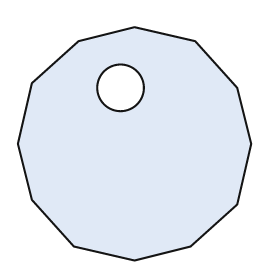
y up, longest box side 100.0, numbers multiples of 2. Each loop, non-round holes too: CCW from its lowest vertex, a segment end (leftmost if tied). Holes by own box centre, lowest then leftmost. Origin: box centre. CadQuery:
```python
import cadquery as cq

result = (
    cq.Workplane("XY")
    .moveTo(0.0, -50.0)
    .lineTo(24.0, -44.0)
    .lineTo(44.0, -26.0)
    .lineTo(50.0, 0.0)
    .lineTo(44.0, 24.0)
    .lineTo(26.0, 44.0)
    .lineTo(0.0, 50.0)
    .lineTo(-24.0, 44.0)
    .lineTo(-44.0, 26.0)
    .lineTo(-50.0, 0.0)
    .lineTo(-44.0, -24.0)
    .lineTo(-26.0, -44.0)
    .close()
    .moveTo(-6.0, 24.0)
    .circle(10.0)
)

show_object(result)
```